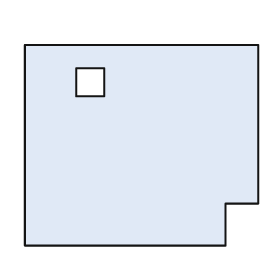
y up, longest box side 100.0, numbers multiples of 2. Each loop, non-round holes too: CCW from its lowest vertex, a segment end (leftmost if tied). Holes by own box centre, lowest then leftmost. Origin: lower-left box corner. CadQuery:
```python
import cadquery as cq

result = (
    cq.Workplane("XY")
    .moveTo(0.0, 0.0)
    .lineTo(86.0, 0.0)
    .lineTo(86.0, 18.0)
    .lineTo(100.0, 18.0)
    .lineTo(100.0, 86.0)
    .lineTo(0.0, 86.0)
    .close()
    .moveTo(22.0, 64.0)
    .lineTo(34.0, 64.0)
    .lineTo(34.0, 76.0)
    .lineTo(22.0, 76.0)
    .close()
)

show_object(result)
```